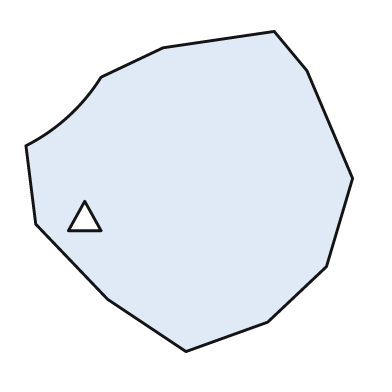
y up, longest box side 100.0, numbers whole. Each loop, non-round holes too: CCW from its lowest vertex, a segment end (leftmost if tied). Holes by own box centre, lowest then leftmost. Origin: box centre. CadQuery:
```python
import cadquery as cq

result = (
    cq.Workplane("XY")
    .moveTo(-1.0, -49.0)
    .lineTo(24.0, -40.0)
    .lineTo(42.0, -23.0)
    .lineTo(50.0, 4.0)
    .lineTo(36.0, 37.0)
    .lineTo(26.0, 49.0)
    .lineTo(-8.0, 44.0)
    .lineTo(-27.0, 35.0)
    .threePointArc((-37.0, 23.0), (-50.0, 14.0))
    .lineTo(-47.0, -10.0)
    .lineTo(-25.0, -33.0)
    .close()
    .moveTo(-37.0, -12.0)
    .lineTo(-27.0, -12.0)
    .lineTo(-32.0, -3.0)
    .close()
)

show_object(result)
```